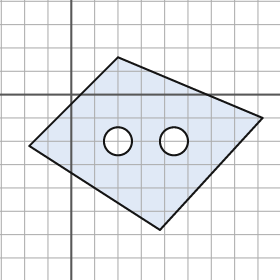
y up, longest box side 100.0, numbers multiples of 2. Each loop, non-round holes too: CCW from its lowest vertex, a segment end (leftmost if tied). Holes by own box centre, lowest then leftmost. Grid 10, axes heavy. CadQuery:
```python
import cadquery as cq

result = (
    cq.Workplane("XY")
    .moveTo(38.0, -58.0)
    .lineTo(82.0, -10.0)
    .lineTo(20.0, 16.0)
    .lineTo(-18.0, -22.0)
    .close()
    .moveTo(20.0, -20.0)
    .circle(6.0)
    .moveTo(44.0, -20.0)
    .circle(6.0)
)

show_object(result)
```